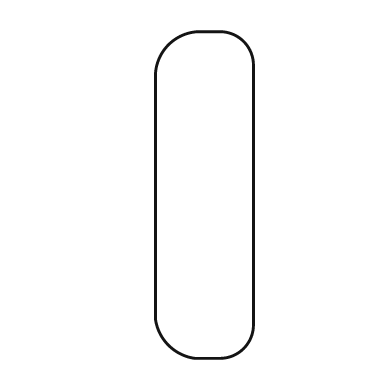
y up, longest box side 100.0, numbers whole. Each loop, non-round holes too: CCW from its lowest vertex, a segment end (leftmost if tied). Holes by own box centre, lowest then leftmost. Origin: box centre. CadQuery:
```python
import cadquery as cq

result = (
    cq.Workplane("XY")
    .moveTo(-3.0, -50.0)
    .lineTo(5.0, -50.0)
    .threePointArc((12.0, -47.0), (15.0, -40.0))
    .lineTo(15.0, 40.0)
    .threePointArc((12.0, 47.0), (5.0, 50.0))
    .lineTo(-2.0, 50.0)
    .threePointArc((-11.0, 46.0), (-15.0, 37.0))
    .lineTo(-15.0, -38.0)
    .threePointArc((-11.0, -46.0), (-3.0, -50.0))
    .close()
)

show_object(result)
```